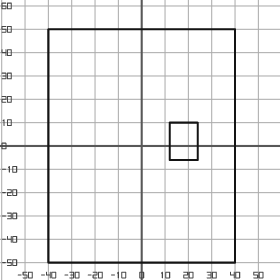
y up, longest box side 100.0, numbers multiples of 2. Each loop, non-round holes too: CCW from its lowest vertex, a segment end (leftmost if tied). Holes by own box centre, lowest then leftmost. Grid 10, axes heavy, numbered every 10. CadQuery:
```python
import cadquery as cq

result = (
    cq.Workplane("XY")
    .moveTo(-40.0, -50.0)
    .lineTo(40.0, -50.0)
    .lineTo(40.0, 50.0)
    .lineTo(-40.0, 50.0)
    .close()
    .moveTo(12.0, -6.0)
    .lineTo(24.0, -6.0)
    .lineTo(24.0, 10.0)
    .lineTo(12.0, 10.0)
    .close()
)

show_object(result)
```